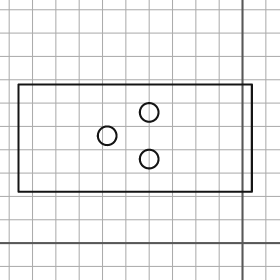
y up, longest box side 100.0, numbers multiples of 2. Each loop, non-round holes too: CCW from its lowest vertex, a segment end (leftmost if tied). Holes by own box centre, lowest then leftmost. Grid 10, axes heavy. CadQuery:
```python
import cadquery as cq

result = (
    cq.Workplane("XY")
    .moveTo(-96.0, 22.0)
    .lineTo(4.0, 22.0)
    .lineTo(4.0, 68.0)
    .lineTo(-96.0, 68.0)
    .close()
    .moveTo(-40.0, 36.0)
    .circle(4.0)
    .moveTo(-58.0, 46.0)
    .circle(4.0)
    .moveTo(-40.0, 56.0)
    .circle(4.0)
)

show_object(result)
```